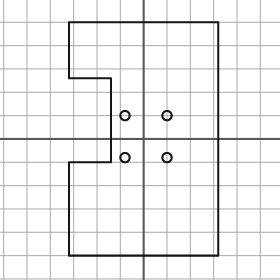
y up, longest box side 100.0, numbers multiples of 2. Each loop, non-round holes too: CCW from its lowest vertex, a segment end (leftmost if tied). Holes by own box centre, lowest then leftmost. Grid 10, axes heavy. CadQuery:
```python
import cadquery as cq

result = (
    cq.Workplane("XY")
    .moveTo(-32.0, -50.0)
    .lineTo(32.0, -50.0)
    .lineTo(32.0, 50.0)
    .lineTo(-32.0, 50.0)
    .lineTo(-32.0, 26.0)
    .lineTo(-14.0, 26.0)
    .lineTo(-14.0, -10.0)
    .lineTo(-32.0, -10.0)
    .close()
    .moveTo(-8.0, -8.0)
    .circle(2.0)
    .moveTo(10.0, -8.0)
    .circle(2.0)
    .moveTo(-8.0, 10.0)
    .circle(2.0)
    .moveTo(10.0, 10.0)
    .circle(2.0)
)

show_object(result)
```